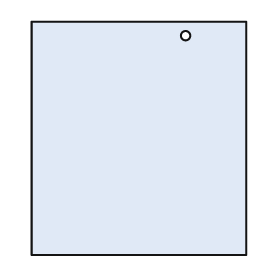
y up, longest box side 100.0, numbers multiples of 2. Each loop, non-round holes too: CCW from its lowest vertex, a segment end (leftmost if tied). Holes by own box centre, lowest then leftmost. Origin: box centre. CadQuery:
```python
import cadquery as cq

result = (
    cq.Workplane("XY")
    .moveTo(-46.0, -50.0)
    .lineTo(46.0, -50.0)
    .lineTo(46.0, 50.0)
    .lineTo(-46.0, 50.0)
    .close()
    .moveTo(20.0, 44.0)
    .circle(2.0)
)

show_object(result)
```